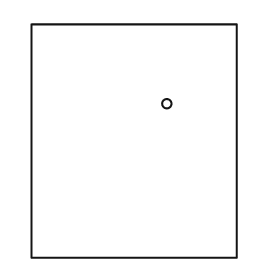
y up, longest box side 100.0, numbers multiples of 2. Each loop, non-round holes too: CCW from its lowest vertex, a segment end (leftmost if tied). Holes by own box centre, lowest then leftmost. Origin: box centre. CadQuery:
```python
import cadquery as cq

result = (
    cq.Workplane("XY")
    .moveTo(-44.0, -50.0)
    .lineTo(44.0, -50.0)
    .lineTo(44.0, 50.0)
    .lineTo(-44.0, 50.0)
    .close()
    .moveTo(14.0, 16.0)
    .circle(2.0)
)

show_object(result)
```